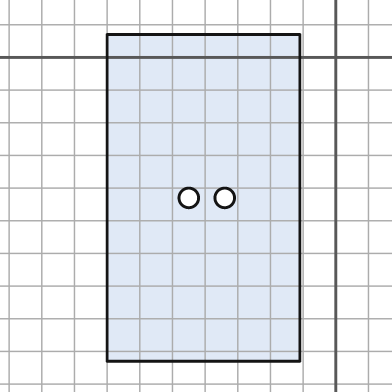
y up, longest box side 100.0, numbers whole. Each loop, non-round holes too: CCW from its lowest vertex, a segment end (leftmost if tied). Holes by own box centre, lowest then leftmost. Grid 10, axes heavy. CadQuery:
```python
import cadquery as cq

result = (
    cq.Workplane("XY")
    .moveTo(-70.0, -93.0)
    .lineTo(-11.0, -93.0)
    .lineTo(-11.0, 7.0)
    .lineTo(-70.0, 7.0)
    .close()
    .moveTo(-45.0, -43.0)
    .circle(3.0)
    .moveTo(-34.0, -43.0)
    .circle(3.0)
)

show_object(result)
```